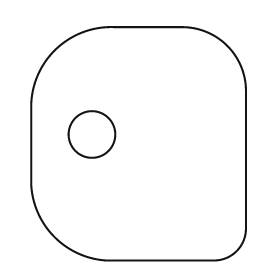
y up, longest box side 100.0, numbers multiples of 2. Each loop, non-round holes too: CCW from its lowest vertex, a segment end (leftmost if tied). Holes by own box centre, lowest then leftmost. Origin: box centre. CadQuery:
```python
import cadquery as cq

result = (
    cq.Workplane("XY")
    .moveTo(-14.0, -50.0)
    .lineTo(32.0, -50.0)
    .threePointArc((42.0, -46.0), (46.0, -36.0))
    .lineTo(46.0, 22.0)
    .threePointArc((38.0, 42.0), (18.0, 50.0))
    .lineTo(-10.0, 50.0)
    .threePointArc((-36.0, 40.0), (-46.0, 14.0))
    .lineTo(-46.0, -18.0)
    .threePointArc((-36.0, -40.0), (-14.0, -50.0))
    .close()
    .moveTo(-20.0, 4.0)
    .circle(10.0)
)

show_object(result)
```